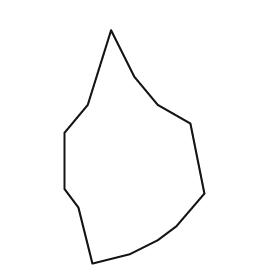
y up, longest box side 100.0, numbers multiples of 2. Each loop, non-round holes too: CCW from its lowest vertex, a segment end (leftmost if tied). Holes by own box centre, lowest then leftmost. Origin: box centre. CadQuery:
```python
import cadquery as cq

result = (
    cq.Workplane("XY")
    .moveTo(-18.0, -50.0)
    .lineTo(-2.0, -46.0)
    .lineTo(10.0, -40.0)
    .lineTo(18.0, -34.0)
    .lineTo(30.0, -20.0)
    .lineTo(24.0, 10.0)
    .lineTo(10.0, 18.0)
    .lineTo(0.0, 30.0)
    .lineTo(-10.0, 50.0)
    .lineTo(-20.0, 18.0)
    .lineTo(-30.0, 6.0)
    .lineTo(-30.0, -18.0)
    .lineTo(-24.0, -26.0)
    .close()
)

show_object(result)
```